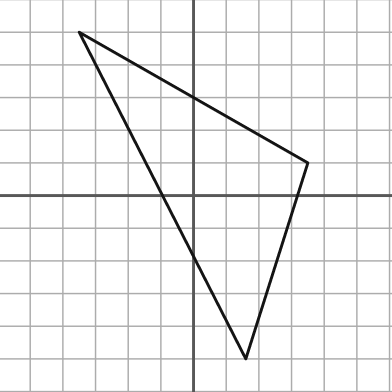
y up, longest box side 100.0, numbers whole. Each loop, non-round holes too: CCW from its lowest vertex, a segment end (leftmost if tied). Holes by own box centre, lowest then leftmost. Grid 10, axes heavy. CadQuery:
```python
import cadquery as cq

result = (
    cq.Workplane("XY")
    .moveTo(16.0, -50.0)
    .lineTo(35.0, 10.0)
    .lineTo(-35.0, 50.0)
    .close()
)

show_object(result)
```